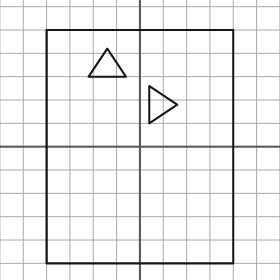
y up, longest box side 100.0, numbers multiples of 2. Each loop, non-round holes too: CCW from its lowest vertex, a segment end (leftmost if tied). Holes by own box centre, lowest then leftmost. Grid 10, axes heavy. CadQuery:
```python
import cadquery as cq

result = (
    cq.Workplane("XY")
    .moveTo(-40.0, -50.0)
    .lineTo(40.0, -50.0)
    .lineTo(40.0, 50.0)
    .lineTo(-40.0, 50.0)
    .close()
    .moveTo(4.0, 10.0)
    .lineTo(16.0, 18.0)
    .lineTo(4.0, 26.0)
    .close()
    .moveTo(-22.0, 30.0)
    .lineTo(-6.0, 30.0)
    .lineTo(-14.0, 42.0)
    .close()
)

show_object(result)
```